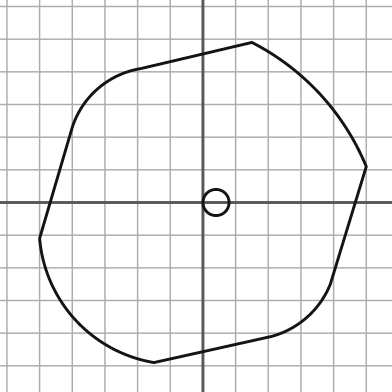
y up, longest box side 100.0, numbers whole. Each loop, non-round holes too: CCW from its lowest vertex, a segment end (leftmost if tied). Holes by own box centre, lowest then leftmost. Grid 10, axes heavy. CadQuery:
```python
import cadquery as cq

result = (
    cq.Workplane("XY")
    .moveTo(-15.0, -49.0)
    .lineTo(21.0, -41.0)
    .threePointArc((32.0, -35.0), (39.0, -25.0))
    .lineTo(50.0, 11.0)
    .threePointArc((36.0, 33.0), (15.0, 49.0))
    .lineTo(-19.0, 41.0)
    .threePointArc((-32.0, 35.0), (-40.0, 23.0))
    .lineTo(-50.0, -11.0)
    .threePointArc((-39.0, -36.0), (-15.0, -49.0))
    .close()
    .moveTo(4.0, 0.0)
    .circle(4.0)
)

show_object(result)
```